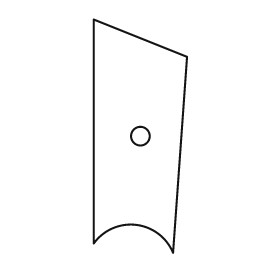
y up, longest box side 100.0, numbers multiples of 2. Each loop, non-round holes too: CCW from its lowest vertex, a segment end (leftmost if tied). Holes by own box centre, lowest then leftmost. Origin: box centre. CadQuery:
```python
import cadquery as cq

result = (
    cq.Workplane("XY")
    .moveTo(14.0, -50.0)
    .lineTo(20.0, 34.0)
    .lineTo(-20.0, 50.0)
    .lineTo(-20.0, -46.0)
    .threePointArc((-2.0, -38.0), (14.0, -50.0))
    .close()
    .moveTo(0.0, 0.0)
    .circle(4.0)
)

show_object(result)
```